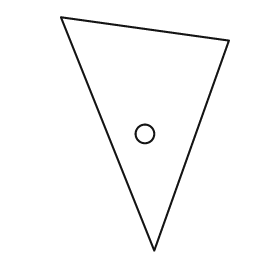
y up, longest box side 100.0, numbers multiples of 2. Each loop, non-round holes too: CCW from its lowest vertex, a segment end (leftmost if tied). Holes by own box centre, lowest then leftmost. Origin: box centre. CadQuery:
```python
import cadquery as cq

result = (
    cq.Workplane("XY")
    .moveTo(4.0, -50.0)
    .lineTo(36.0, 40.0)
    .lineTo(-36.0, 50.0)
    .close()
    .moveTo(0.0, 0.0)
    .circle(4.0)
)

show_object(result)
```